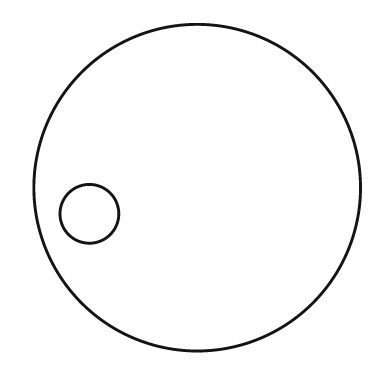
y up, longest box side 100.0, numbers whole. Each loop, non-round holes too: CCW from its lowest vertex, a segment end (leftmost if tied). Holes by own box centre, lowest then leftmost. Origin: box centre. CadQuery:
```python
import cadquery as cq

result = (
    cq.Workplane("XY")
    .moveTo(0.0, 0.0)
    .circle(50.0)
    .moveTo(-33.0, -8.0)
    .circle(9.0)
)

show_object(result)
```